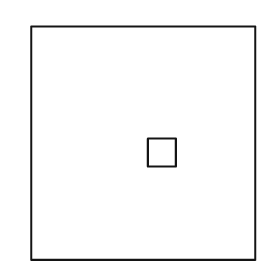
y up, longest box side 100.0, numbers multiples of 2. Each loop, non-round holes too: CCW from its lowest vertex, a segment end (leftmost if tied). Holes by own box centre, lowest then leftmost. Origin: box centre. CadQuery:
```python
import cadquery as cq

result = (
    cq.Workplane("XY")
    .moveTo(-48.0, -50.0)
    .lineTo(48.0, -50.0)
    .lineTo(48.0, 50.0)
    .lineTo(-48.0, 50.0)
    .close()
    .moveTo(2.0, -10.0)
    .lineTo(14.0, -10.0)
    .lineTo(14.0, 2.0)
    .lineTo(2.0, 2.0)
    .close()
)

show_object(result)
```